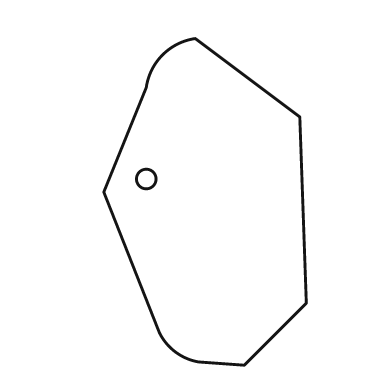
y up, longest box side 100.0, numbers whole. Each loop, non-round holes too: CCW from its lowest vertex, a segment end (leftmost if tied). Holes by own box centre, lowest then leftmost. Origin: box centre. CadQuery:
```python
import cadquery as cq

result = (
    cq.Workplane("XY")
    .moveTo(12.0, -50.0)
    .lineTo(31.0, -31.0)
    .lineTo(29.0, 26.0)
    .lineTo(-3.0, 50.0)
    .threePointArc((-13.0, 45.0), (-18.0, 35.0))
    .lineTo(-31.0, 3.0)
    .lineTo(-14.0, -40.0)
    .threePointArc((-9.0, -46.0), (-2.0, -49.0))
    .close()
    .moveTo(-18.0, 7.0)
    .circle(3.0)
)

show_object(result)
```